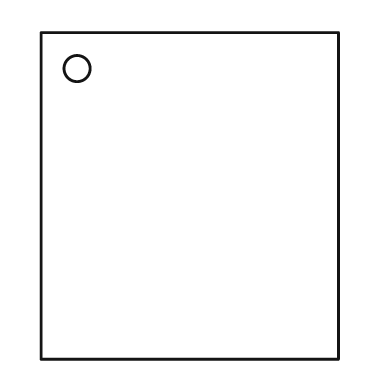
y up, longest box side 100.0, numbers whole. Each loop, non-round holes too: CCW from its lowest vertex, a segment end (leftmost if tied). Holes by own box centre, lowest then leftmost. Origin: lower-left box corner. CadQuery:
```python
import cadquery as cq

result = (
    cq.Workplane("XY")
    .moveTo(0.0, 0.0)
    .lineTo(91.0, 0.0)
    .lineTo(91.0, 100.0)
    .lineTo(0.0, 100.0)
    .close()
    .moveTo(11.0, 89.0)
    .circle(4.0)
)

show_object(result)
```